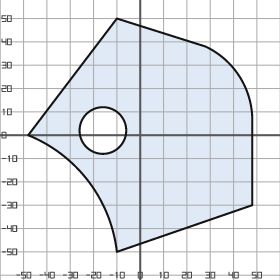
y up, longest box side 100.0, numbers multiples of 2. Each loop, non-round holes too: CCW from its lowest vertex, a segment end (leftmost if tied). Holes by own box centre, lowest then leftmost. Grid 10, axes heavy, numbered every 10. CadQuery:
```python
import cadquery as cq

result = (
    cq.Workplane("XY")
    .moveTo(-10.0, -50.0)
    .lineTo(48.0, -30.0)
    .lineTo(48.0, 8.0)
    .threePointArc((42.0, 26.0), (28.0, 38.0))
    .lineTo(-10.0, 50.0)
    .lineTo(-48.0, 0.0)
    .threePointArc((-22.0, -20.0), (-10.0, -50.0))
    .close()
    .moveTo(-16.0, 2.0)
    .circle(10.0)
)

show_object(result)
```